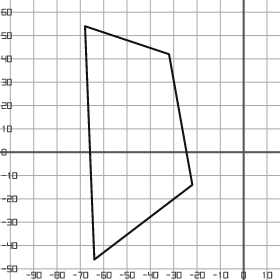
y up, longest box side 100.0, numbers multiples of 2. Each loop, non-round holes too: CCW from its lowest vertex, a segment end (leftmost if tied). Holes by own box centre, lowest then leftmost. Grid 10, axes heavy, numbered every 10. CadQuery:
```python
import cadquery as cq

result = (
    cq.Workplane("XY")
    .moveTo(-64.0, -46.0)
    .lineTo(-22.0, -14.0)
    .lineTo(-32.0, 42.0)
    .lineTo(-68.0, 54.0)
    .close()
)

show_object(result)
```